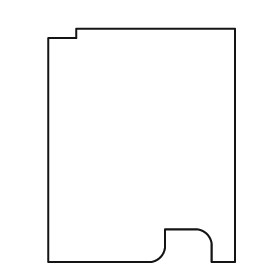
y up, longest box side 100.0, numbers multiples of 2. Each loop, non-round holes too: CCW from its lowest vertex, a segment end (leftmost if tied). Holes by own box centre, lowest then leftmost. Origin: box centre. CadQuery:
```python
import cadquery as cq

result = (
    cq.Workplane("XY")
    .moveTo(-40.0, -50.0)
    .lineTo(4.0, -50.0)
    .threePointArc((8.0, -48.0), (10.0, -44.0))
    .lineTo(10.0, -36.0)
    .lineTo(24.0, -36.0)
    .threePointArc((28.0, -38.0), (30.0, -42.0))
    .lineTo(30.0, -50.0)
    .lineTo(40.0, -50.0)
    .lineTo(40.0, 50.0)
    .lineTo(-28.0, 50.0)
    .lineTo(-28.0, 46.0)
    .lineTo(-40.0, 46.0)
    .close()
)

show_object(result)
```